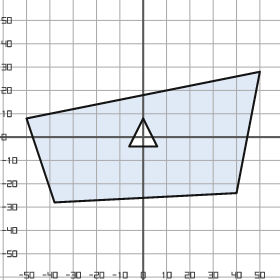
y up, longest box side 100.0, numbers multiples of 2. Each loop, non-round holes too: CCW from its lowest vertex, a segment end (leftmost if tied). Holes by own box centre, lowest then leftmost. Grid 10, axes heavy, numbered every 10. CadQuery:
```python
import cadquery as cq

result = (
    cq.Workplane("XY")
    .moveTo(-38.0, -28.0)
    .lineTo(40.0, -24.0)
    .lineTo(50.0, 28.0)
    .lineTo(-50.0, 8.0)
    .close()
    .moveTo(-6.0, -4.0)
    .lineTo(6.0, -4.0)
    .lineTo(0.0, 8.0)
    .close()
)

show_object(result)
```